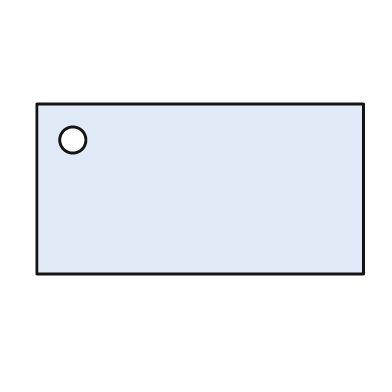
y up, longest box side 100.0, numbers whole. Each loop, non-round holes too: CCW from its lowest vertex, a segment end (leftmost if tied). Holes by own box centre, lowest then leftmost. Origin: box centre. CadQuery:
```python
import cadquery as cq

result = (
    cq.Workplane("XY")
    .moveTo(-50.0, -26.0)
    .lineTo(50.0, -26.0)
    .lineTo(50.0, 26.0)
    .lineTo(-50.0, 26.0)
    .close()
    .moveTo(-39.0, 15.0)
    .circle(4.0)
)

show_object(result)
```